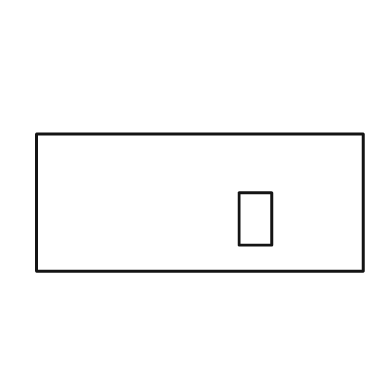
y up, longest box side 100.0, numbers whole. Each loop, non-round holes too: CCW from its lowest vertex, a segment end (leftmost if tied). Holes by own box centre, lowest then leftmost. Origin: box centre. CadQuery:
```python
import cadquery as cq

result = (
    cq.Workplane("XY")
    .moveTo(-50.0, -21.0)
    .lineTo(50.0, -21.0)
    .lineTo(50.0, 21.0)
    .lineTo(-50.0, 21.0)
    .close()
    .moveTo(12.0, -13.0)
    .lineTo(22.0, -13.0)
    .lineTo(22.0, 3.0)
    .lineTo(12.0, 3.0)
    .close()
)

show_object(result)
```